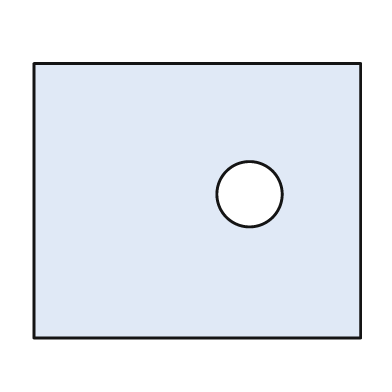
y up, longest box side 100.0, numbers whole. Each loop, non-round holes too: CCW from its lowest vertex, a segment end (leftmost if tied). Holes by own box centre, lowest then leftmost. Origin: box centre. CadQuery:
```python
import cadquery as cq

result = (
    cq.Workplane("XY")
    .moveTo(-50.0, -42.0)
    .lineTo(50.0, -42.0)
    .lineTo(50.0, 42.0)
    .lineTo(-50.0, 42.0)
    .close()
    .moveTo(16.0, 2.0)
    .circle(10.0)
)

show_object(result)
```